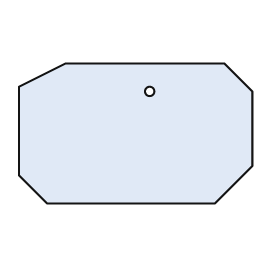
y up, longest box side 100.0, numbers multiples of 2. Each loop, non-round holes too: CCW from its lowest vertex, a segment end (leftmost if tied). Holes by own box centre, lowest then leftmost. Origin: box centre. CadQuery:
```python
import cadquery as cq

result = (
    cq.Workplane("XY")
    .moveTo(-38.0, -30.0)
    .lineTo(34.0, -30.0)
    .lineTo(50.0, -14.0)
    .lineTo(50.0, 18.0)
    .lineTo(38.0, 30.0)
    .lineTo(-30.0, 30.0)
    .lineTo(-50.0, 20.0)
    .lineTo(-50.0, -18.0)
    .close()
    .moveTo(6.0, 18.0)
    .circle(2.0)
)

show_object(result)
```